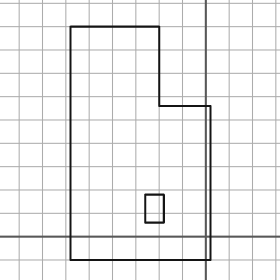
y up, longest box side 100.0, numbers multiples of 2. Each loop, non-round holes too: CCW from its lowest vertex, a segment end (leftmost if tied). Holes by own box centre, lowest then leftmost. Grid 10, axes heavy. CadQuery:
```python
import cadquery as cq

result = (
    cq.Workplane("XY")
    .moveTo(-58.0, -10.0)
    .lineTo(2.0, -10.0)
    .lineTo(2.0, 56.0)
    .lineTo(-20.0, 56.0)
    .lineTo(-20.0, 90.0)
    .lineTo(-58.0, 90.0)
    .close()
    .moveTo(-26.0, 6.0)
    .lineTo(-18.0, 6.0)
    .lineTo(-18.0, 18.0)
    .lineTo(-26.0, 18.0)
    .close()
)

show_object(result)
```